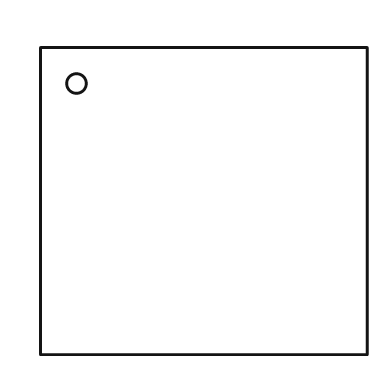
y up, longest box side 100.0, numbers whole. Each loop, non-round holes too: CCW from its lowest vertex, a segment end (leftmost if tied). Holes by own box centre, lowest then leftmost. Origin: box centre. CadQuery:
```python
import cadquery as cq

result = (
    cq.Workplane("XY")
    .moveTo(-50.0, -47.0)
    .lineTo(50.0, -47.0)
    .lineTo(50.0, 47.0)
    .lineTo(-50.0, 47.0)
    .close()
    .moveTo(-39.0, 36.0)
    .circle(3.0)
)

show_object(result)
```